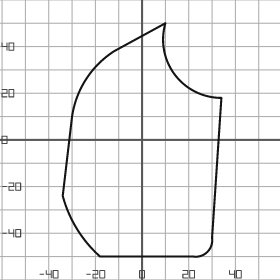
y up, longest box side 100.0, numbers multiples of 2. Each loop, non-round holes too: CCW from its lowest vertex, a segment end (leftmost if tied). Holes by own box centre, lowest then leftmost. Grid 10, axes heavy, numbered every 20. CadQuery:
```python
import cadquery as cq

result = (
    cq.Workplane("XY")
    .moveTo(-18.0, -50.0)
    .lineTo(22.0, -50.0)
    .threePointArc((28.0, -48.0), (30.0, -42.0))
    .lineTo(34.0, 18.0)
    .threePointArc((14.0, 28.0), (10.0, 50.0))
    .lineTo(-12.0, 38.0)
    .threePointArc((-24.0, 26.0), (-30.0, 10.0))
    .lineTo(-34.0, -24.0)
    .threePointArc((-28.0, -38.0), (-18.0, -50.0))
    .close()
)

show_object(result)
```